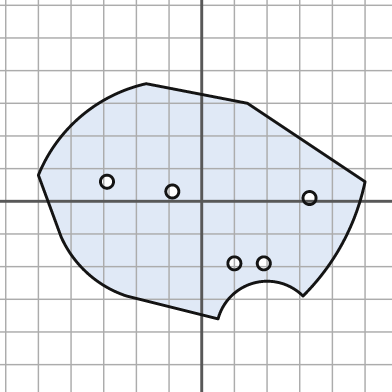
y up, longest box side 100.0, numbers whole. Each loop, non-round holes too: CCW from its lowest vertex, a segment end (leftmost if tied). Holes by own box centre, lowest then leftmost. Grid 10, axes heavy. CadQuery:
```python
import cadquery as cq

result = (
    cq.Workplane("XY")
    .moveTo(5.0, -36.0)
    .threePointArc((16.0, -25.0), (31.0, -29.0))
    .threePointArc((43.0, -13.0), (50.0, 6.0))
    .lineTo(14.0, 30.0)
    .lineTo(-17.0, 36.0)
    .threePointArc((-37.0, 26.0), (-50.0, 8.0))
    .lineTo(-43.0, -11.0)
    .threePointArc((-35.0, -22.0), (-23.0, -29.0))
    .close()
    .moveTo(10.0, -19.0)
    .circle(2.0)
    .moveTo(19.0, -19.0)
    .circle(2.0)
    .moveTo(33.0, 1.0)
    .circle(2.0)
    .moveTo(-9.0, 3.0)
    .circle(2.0)
    .moveTo(-29.0, 6.0)
    .circle(2.0)
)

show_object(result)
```